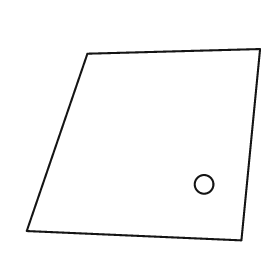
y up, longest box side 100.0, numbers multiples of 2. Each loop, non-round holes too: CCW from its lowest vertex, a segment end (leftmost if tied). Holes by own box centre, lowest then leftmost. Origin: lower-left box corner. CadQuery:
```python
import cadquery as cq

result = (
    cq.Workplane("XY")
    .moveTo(92.0, 0.0)
    .lineTo(100.0, 82.0)
    .lineTo(26.0, 80.0)
    .lineTo(0.0, 4.0)
    .close()
    .moveTo(76.0, 24.0)
    .circle(4.0)
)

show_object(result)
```